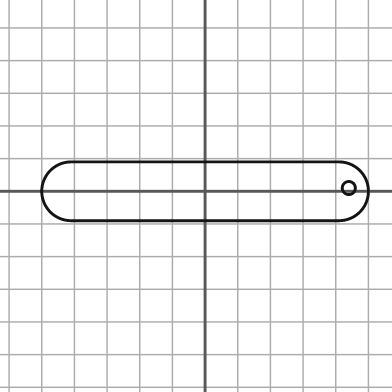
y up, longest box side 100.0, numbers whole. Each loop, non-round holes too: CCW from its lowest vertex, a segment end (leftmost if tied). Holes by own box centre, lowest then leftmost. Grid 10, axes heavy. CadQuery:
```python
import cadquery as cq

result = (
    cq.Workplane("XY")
    .moveTo(-41.0, -9.0)
    .lineTo(41.0, -9.0)
    .threePointArc((50.0, 0.0), (41.0, 9.0))
    .lineTo(-41.0, 9.0)
    .threePointArc((-50.0, 0.0), (-41.0, -9.0))
    .close()
    .moveTo(44.0, 1.0)
    .circle(2.0)
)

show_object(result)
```